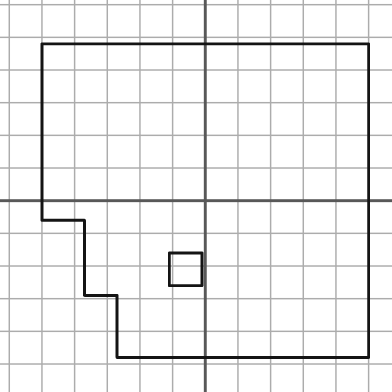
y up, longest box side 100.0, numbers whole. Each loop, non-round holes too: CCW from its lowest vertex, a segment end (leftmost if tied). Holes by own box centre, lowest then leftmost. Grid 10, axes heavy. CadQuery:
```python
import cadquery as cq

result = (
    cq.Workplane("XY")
    .moveTo(-27.0, -48.0)
    .lineTo(50.0, -48.0)
    .lineTo(50.0, 48.0)
    .lineTo(-50.0, 48.0)
    .lineTo(-50.0, -6.0)
    .lineTo(-37.0, -6.0)
    .lineTo(-37.0, -29.0)
    .lineTo(-27.0, -29.0)
    .close()
    .moveTo(-11.0, -26.0)
    .lineTo(-1.0, -26.0)
    .lineTo(-1.0, -16.0)
    .lineTo(-11.0, -16.0)
    .close()
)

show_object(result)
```